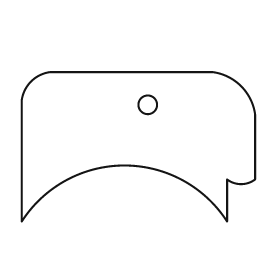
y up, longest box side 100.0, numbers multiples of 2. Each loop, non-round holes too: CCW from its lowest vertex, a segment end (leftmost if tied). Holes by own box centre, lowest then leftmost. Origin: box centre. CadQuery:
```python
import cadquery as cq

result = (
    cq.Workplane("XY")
    .moveTo(-50.0, -32.0)
    .threePointArc((-6.0, -8.0), (38.0, -32.0))
    .lineTo(38.0, -14.0)
    .threePointArc((44.0, -16.0), (50.0, -14.0))
    .lineTo(50.0, 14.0)
    .threePointArc((44.0, 26.0), (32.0, 32.0))
    .lineTo(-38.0, 32.0)
    .threePointArc((-46.0, 28.0), (-50.0, 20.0))
    .close()
    .moveTo(4.0, 18.0)
    .circle(4.0)
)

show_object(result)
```